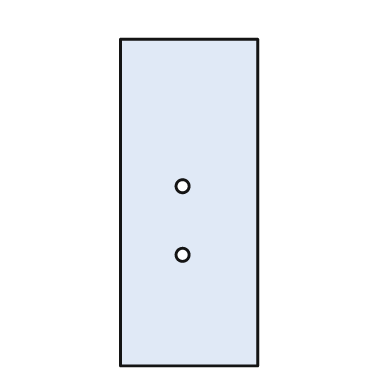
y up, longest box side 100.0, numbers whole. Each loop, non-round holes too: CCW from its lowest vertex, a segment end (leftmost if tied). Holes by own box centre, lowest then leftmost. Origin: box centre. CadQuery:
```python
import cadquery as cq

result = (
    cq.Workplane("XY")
    .moveTo(-21.0, -50.0)
    .lineTo(21.0, -50.0)
    .lineTo(21.0, 50.0)
    .lineTo(-21.0, 50.0)
    .close()
    .moveTo(-2.0, -16.0)
    .circle(2.0)
    .moveTo(-2.0, 5.0)
    .circle(2.0)
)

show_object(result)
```